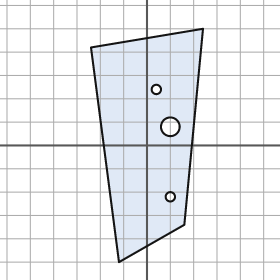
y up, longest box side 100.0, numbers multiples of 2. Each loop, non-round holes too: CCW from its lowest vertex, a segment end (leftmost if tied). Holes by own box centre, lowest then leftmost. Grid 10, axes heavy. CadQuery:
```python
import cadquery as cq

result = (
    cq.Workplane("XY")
    .moveTo(-12.0, -50.0)
    .lineTo(16.0, -34.0)
    .lineTo(24.0, 50.0)
    .lineTo(-24.0, 42.0)
    .close()
    .moveTo(10.0, -22.0)
    .circle(2.0)
    .moveTo(10.0, 8.0)
    .circle(4.0)
    .moveTo(4.0, 24.0)
    .circle(2.0)
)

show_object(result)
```